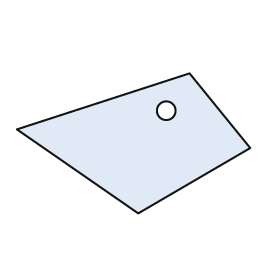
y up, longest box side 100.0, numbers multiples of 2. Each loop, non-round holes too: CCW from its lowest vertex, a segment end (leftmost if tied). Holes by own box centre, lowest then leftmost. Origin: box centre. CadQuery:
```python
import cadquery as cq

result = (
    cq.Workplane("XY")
    .moveTo(2.0, -30.0)
    .lineTo(50.0, -2.0)
    .lineTo(24.0, 30.0)
    .lineTo(-50.0, 6.0)
    .close()
    .moveTo(14.0, 14.0)
    .circle(4.0)
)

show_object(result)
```